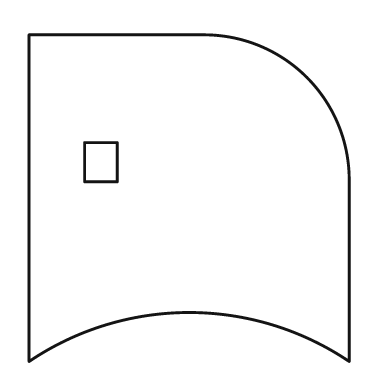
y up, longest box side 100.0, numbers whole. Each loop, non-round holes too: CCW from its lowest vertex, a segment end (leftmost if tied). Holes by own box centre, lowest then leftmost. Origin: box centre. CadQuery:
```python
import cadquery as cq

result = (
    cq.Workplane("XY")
    .moveTo(-49.0, -50.0)
    .threePointArc((0.0, -35.0), (49.0, -50.0))
    .lineTo(49.0, 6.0)
    .threePointArc((36.0, 37.0), (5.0, 50.0))
    .lineTo(-49.0, 50.0)
    .close()
    .moveTo(-32.0, 5.0)
    .lineTo(-22.0, 5.0)
    .lineTo(-22.0, 17.0)
    .lineTo(-32.0, 17.0)
    .close()
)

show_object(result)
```